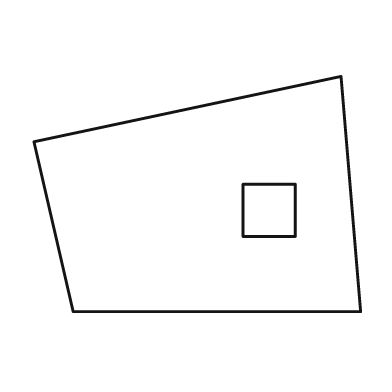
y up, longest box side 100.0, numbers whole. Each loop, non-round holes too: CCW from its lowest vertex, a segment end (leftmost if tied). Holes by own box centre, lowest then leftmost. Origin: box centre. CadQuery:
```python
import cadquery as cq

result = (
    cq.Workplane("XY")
    .moveTo(-38.0, -36.0)
    .lineTo(50.0, -36.0)
    .lineTo(44.0, 36.0)
    .lineTo(-50.0, 16.0)
    .close()
    .moveTo(14.0, -13.0)
    .lineTo(30.0, -13.0)
    .lineTo(30.0, 3.0)
    .lineTo(14.0, 3.0)
    .close()
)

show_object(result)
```